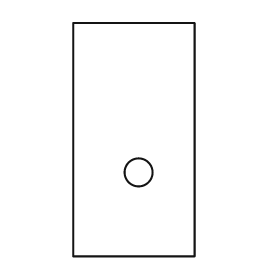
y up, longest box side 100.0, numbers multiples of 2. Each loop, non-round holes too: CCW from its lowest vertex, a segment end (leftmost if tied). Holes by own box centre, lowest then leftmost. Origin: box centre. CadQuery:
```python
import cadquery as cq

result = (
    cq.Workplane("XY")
    .moveTo(-26.0, -50.0)
    .lineTo(26.0, -50.0)
    .lineTo(26.0, 50.0)
    .lineTo(-26.0, 50.0)
    .close()
    .moveTo(2.0, -14.0)
    .circle(6.0)
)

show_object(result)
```